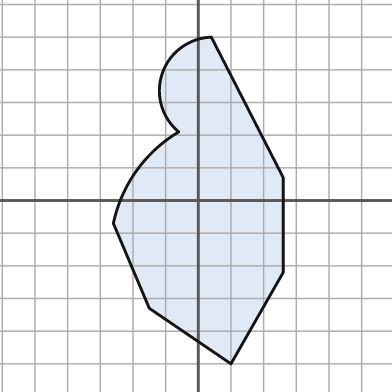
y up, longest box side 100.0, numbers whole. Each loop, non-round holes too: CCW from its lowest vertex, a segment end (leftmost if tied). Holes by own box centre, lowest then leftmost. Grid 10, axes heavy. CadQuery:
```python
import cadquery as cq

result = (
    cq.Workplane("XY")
    .moveTo(10.0, -50.0)
    .lineTo(26.0, -22.0)
    .lineTo(26.0, 7.0)
    .lineTo(4.0, 50.0)
    .threePointArc((-11.0, 39.0), (-6.0, 21.0))
    .threePointArc((-19.0, 9.0), (-26.0, -7.0))
    .lineTo(-15.0, -33.0)
    .close()
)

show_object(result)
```